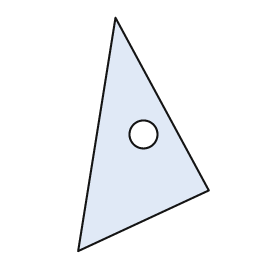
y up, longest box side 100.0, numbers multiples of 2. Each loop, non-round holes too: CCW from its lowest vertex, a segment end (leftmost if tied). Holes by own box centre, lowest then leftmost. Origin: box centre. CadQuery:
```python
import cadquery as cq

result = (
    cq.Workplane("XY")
    .moveTo(-28.0, -50.0)
    .lineTo(28.0, -24.0)
    .lineTo(-12.0, 50.0)
    .close()
    .moveTo(0.0, 0.0)
    .circle(6.0)
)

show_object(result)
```